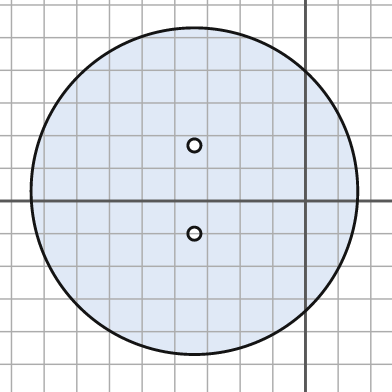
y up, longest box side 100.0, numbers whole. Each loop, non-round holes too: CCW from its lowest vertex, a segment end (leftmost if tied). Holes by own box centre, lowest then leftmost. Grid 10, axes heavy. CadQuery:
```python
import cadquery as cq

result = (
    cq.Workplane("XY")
    .moveTo(-34.0, 3.0)
    .circle(50.0)
    .moveTo(-34.0, -10.0)
    .circle(2.0)
    .moveTo(-34.0, 17.0)
    .circle(2.0)
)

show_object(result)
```